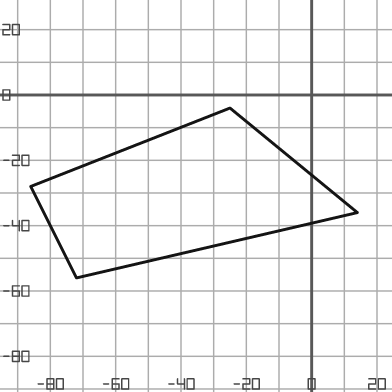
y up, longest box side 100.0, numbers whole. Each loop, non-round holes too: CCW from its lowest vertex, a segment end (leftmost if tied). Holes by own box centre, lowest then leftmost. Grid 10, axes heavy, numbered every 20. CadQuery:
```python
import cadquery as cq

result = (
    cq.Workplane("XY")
    .moveTo(-72.0, -56.0)
    .lineTo(14.0, -36.0)
    .lineTo(-25.0, -4.0)
    .lineTo(-86.0, -28.0)
    .close()
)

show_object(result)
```